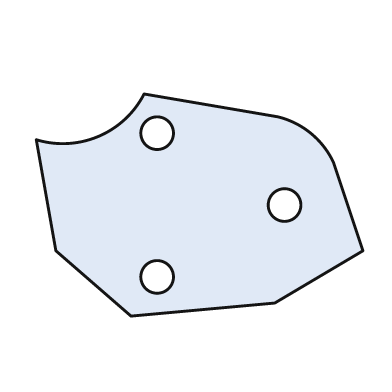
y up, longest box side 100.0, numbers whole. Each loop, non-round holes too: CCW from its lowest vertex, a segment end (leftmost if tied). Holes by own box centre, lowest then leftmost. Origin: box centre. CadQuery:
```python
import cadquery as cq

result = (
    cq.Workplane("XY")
    .moveTo(-21.0, -34.0)
    .lineTo(23.0, -30.0)
    .lineTo(50.0, -14.0)
    .lineTo(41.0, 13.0)
    .threePointArc((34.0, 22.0), (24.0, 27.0))
    .lineTo(-17.0, 34.0)
    .threePointArc((-31.0, 21.0), (-50.0, 20.0))
    .lineTo(-44.0, -14.0)
    .close()
    .moveTo(-13.0, -22.0)
    .circle(5.0)
    .moveTo(26.0, 0.0)
    .circle(5.0)
    .moveTo(-13.0, 22.0)
    .circle(5.0)
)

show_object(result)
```